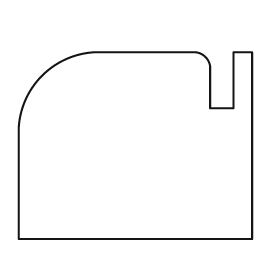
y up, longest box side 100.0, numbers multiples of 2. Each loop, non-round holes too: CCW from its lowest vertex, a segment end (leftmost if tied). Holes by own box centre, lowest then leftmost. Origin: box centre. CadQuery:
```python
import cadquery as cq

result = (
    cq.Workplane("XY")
    .moveTo(-50.0, -40.0)
    .lineTo(50.0, -40.0)
    .lineTo(50.0, 40.0)
    .lineTo(42.0, 40.0)
    .lineTo(42.0, 16.0)
    .lineTo(32.0, 16.0)
    .lineTo(32.0, 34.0)
    .threePointArc((30.0, 38.0), (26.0, 40.0))
    .lineTo(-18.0, 40.0)
    .threePointArc((-40.0, 30.0), (-50.0, 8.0))
    .close()
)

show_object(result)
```